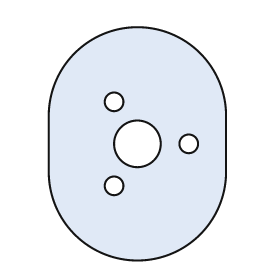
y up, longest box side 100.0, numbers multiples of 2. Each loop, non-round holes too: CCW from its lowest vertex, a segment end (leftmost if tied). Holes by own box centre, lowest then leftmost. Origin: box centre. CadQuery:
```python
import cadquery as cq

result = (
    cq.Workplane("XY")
    .moveTo(-38.0, -12.0)
    .threePointArc((0.0, -50.0), (38.0, -12.0))
    .lineTo(38.0, 12.0)
    .threePointArc((0.0, 50.0), (-38.0, 12.0))
    .close()
    .moveTo(-10.0, -18.0)
    .circle(4.0)
    .moveTo(0.0, 0.0)
    .circle(10.0)
    .moveTo(22.0, 0.0)
    .circle(4.0)
    .moveTo(-10.0, 18.0)
    .circle(4.0)
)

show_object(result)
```